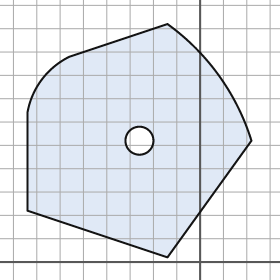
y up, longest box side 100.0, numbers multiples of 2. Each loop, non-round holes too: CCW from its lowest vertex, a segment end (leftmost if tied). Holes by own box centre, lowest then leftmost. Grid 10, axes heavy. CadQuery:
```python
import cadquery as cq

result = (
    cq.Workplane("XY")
    .moveTo(-14.0, 2.0)
    .lineTo(22.0, 52.0)
    .threePointArc((8.0, 80.0), (-14.0, 102.0))
    .lineTo(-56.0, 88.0)
    .threePointArc((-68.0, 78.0), (-74.0, 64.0))
    .lineTo(-74.0, 22.0)
    .close()
    .moveTo(-26.0, 52.0)
    .circle(6.0)
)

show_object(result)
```